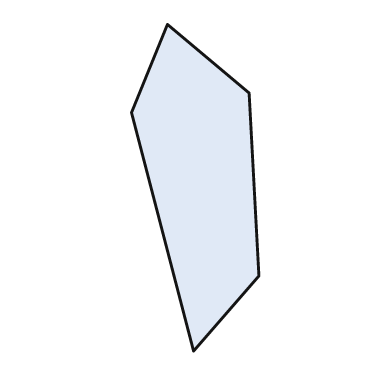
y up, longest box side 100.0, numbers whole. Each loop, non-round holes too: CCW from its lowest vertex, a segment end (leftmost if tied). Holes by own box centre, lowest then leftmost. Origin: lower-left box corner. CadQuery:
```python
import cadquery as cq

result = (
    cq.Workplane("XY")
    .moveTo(19.0, 0.0)
    .lineTo(39.0, 23.0)
    .lineTo(36.0, 79.0)
    .lineTo(11.0, 100.0)
    .lineTo(0.0, 73.0)
    .close()
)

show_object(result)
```